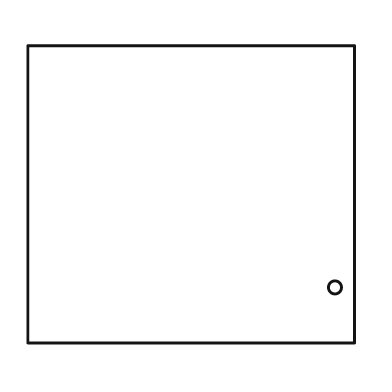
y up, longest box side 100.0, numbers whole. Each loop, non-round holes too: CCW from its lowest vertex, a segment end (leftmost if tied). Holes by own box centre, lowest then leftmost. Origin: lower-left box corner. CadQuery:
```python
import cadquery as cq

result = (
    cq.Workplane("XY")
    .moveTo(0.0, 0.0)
    .lineTo(100.0, 0.0)
    .lineTo(100.0, 91.0)
    .lineTo(0.0, 91.0)
    .close()
    .moveTo(94.0, 17.0)
    .circle(2.0)
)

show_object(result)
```